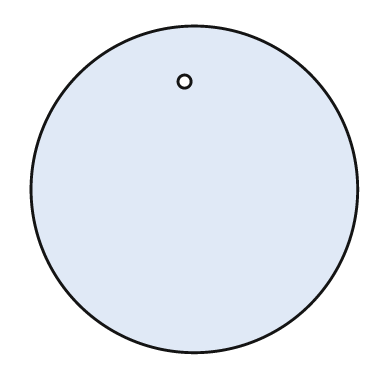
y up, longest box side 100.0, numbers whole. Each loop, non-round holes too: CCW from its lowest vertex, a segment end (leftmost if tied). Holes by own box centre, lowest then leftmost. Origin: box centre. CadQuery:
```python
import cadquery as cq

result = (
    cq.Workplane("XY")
    .moveTo(0.0, 0.0)
    .circle(50.0)
    .moveTo(-3.0, 33.0)
    .circle(2.0)
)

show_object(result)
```